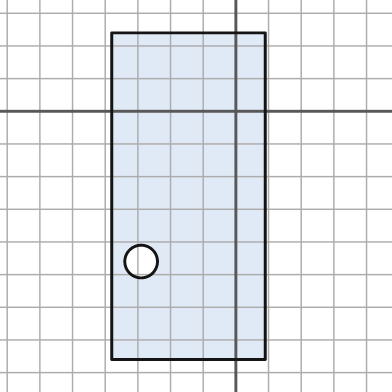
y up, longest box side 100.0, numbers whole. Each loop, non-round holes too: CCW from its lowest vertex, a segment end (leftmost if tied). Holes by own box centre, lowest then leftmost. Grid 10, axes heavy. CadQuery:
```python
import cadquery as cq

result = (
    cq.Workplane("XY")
    .moveTo(-38.0, -76.0)
    .lineTo(9.0, -76.0)
    .lineTo(9.0, 24.0)
    .lineTo(-38.0, 24.0)
    .close()
    .moveTo(-29.0, -46.0)
    .circle(5.0)
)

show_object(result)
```